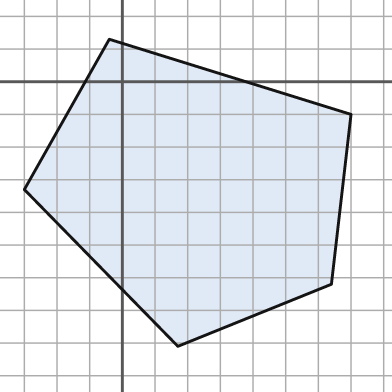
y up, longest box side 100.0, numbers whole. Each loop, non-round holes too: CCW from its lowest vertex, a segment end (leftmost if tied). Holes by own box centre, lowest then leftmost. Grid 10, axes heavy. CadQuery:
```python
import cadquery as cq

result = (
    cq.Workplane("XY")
    .moveTo(17.0, -81.0)
    .lineTo(64.0, -62.0)
    .lineTo(70.0, -10.0)
    .lineTo(-4.0, 13.0)
    .lineTo(-30.0, -33.0)
    .close()
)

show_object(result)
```